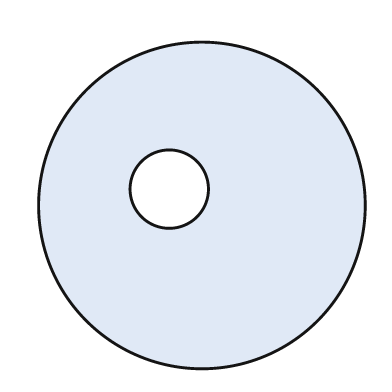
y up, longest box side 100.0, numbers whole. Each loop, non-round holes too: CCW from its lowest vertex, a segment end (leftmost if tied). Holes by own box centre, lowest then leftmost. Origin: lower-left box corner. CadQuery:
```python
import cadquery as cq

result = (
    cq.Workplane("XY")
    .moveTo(50.0, 50.0)
    .circle(50.0)
    .moveTo(40.0, 55.0)
    .circle(12.0)
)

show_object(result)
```